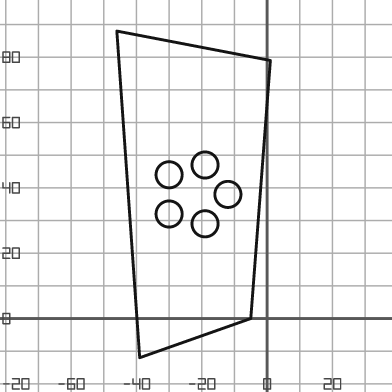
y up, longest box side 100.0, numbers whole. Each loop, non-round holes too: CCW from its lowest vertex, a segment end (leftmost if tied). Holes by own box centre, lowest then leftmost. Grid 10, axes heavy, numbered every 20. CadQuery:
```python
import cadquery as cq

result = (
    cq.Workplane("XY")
    .moveTo(-39.0, -12.0)
    .lineTo(-5.0, 0.0)
    .lineTo(1.0, 79.0)
    .lineTo(-46.0, 88.0)
    .close()
    .moveTo(-19.0, 29.0)
    .circle(4.0)
    .moveTo(-30.0, 32.0)
    .circle(4.0)
    .moveTo(-12.0, 38.0)
    .circle(4.0)
    .moveTo(-30.0, 44.0)
    .circle(4.0)
    .moveTo(-19.0, 47.0)
    .circle(4.0)
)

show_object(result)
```